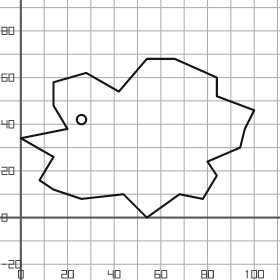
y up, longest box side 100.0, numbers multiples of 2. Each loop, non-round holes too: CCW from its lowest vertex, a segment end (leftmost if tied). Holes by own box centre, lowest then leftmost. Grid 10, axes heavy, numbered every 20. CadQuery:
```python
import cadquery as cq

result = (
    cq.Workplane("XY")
    .moveTo(54.0, 0.0)
    .lineTo(68.0, 10.0)
    .lineTo(78.0, 8.0)
    .lineTo(84.0, 18.0)
    .lineTo(80.0, 24.0)
    .lineTo(94.0, 30.0)
    .lineTo(96.0, 38.0)
    .lineTo(100.0, 46.0)
    .lineTo(84.0, 52.0)
    .lineTo(84.0, 60.0)
    .lineTo(66.0, 68.0)
    .lineTo(54.0, 68.0)
    .lineTo(42.0, 54.0)
    .lineTo(28.0, 62.0)
    .lineTo(14.0, 58.0)
    .lineTo(14.0, 48.0)
    .lineTo(20.0, 38.0)
    .lineTo(0.0, 34.0)
    .lineTo(14.0, 26.0)
    .lineTo(8.0, 16.0)
    .lineTo(14.0, 12.0)
    .lineTo(26.0, 8.0)
    .lineTo(44.0, 10.0)
    .close()
    .moveTo(26.0, 42.0)
    .circle(2.0)
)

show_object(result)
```